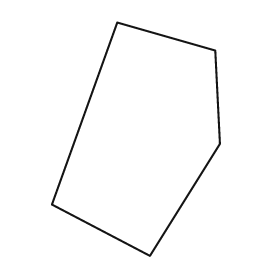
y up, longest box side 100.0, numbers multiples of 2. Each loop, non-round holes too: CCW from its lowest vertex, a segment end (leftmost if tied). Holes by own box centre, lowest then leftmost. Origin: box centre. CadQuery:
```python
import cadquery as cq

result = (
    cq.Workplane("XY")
    .moveTo(6.0, -50.0)
    .lineTo(36.0, -2.0)
    .lineTo(34.0, 38.0)
    .lineTo(-8.0, 50.0)
    .lineTo(-36.0, -28.0)
    .close()
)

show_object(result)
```